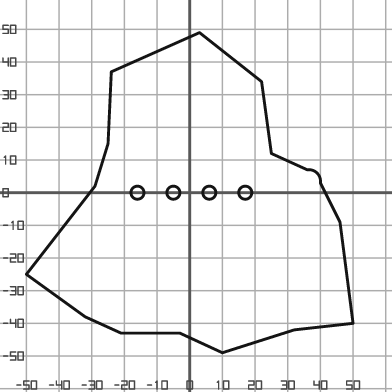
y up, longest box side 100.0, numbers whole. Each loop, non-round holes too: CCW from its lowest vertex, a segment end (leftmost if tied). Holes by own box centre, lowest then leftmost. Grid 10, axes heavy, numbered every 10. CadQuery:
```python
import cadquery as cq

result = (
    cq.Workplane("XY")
    .moveTo(10.0, -49.0)
    .lineTo(32.0, -42.0)
    .lineTo(50.0, -40.0)
    .lineTo(46.0, -9.0)
    .lineTo(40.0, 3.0)
    .threePointArc((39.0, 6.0), (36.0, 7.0))
    .lineTo(25.0, 12.0)
    .lineTo(22.0, 34.0)
    .lineTo(3.0, 49.0)
    .lineTo(-24.0, 37.0)
    .lineTo(-25.0, 15.0)
    .lineTo(-29.0, 2.0)
    .lineTo(-50.0, -25.0)
    .lineTo(-32.0, -38.0)
    .lineTo(-21.0, -43.0)
    .lineTo(-3.0, -43.0)
    .close()
    .moveTo(-16.0, 0.0)
    .circle(2.0)
    .moveTo(-5.0, 0.0)
    .circle(2.0)
    .moveTo(6.0, 0.0)
    .circle(2.0)
    .moveTo(17.0, 0.0)
    .circle(2.0)
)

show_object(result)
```